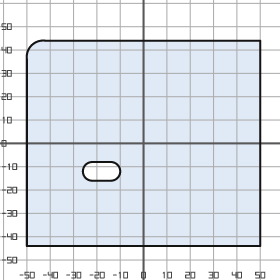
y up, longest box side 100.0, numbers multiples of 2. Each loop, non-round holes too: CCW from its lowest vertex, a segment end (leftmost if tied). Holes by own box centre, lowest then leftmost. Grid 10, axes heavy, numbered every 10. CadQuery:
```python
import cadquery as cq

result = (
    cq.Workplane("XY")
    .moveTo(-50.0, -44.0)
    .lineTo(50.0, -44.0)
    .lineTo(50.0, 44.0)
    .lineTo(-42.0, 44.0)
    .threePointArc((-48.0, 42.0), (-50.0, 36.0))
    .close()
    .moveTo(-22.0, -16.0)
    .lineTo(-14.0, -16.0)
    .threePointArc((-10.0, -12.0), (-14.0, -8.0))
    .lineTo(-22.0, -8.0)
    .threePointArc((-26.0, -12.0), (-22.0, -16.0))
    .close()
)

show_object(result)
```